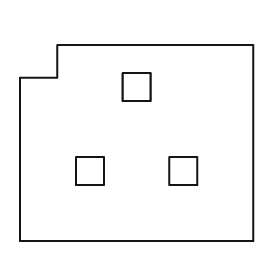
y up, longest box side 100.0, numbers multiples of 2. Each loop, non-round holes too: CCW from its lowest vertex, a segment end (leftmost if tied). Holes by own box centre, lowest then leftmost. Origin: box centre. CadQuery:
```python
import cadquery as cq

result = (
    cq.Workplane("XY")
    .moveTo(-50.0, -42.0)
    .lineTo(50.0, -42.0)
    .lineTo(50.0, 42.0)
    .lineTo(-34.0, 42.0)
    .lineTo(-34.0, 28.0)
    .lineTo(-50.0, 28.0)
    .close()
    .moveTo(-26.0, -18.0)
    .lineTo(-14.0, -18.0)
    .lineTo(-14.0, -6.0)
    .lineTo(-26.0, -6.0)
    .close()
    .moveTo(14.0, -18.0)
    .lineTo(26.0, -18.0)
    .lineTo(26.0, -6.0)
    .lineTo(14.0, -6.0)
    .close()
    .moveTo(-6.0, 18.0)
    .lineTo(6.0, 18.0)
    .lineTo(6.0, 30.0)
    .lineTo(-6.0, 30.0)
    .close()
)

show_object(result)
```